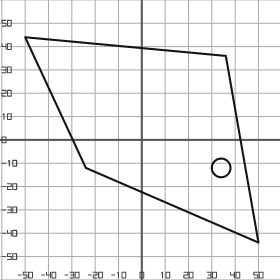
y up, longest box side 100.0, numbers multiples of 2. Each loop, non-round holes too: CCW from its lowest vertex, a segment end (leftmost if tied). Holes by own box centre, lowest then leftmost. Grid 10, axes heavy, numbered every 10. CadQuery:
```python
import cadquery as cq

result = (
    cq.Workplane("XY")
    .moveTo(50.0, -44.0)
    .lineTo(36.0, 36.0)
    .lineTo(-50.0, 44.0)
    .lineTo(-24.0, -12.0)
    .close()
    .moveTo(34.0, -12.0)
    .circle(4.0)
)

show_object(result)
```